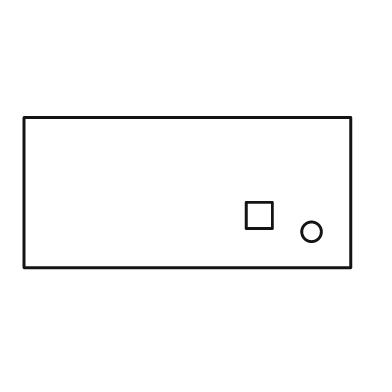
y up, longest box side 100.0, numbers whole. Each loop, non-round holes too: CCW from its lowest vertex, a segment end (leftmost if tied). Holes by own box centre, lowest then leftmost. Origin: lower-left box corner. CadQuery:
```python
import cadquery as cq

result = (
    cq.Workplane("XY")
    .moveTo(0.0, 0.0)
    .lineTo(100.0, 0.0)
    .lineTo(100.0, 46.0)
    .lineTo(0.0, 46.0)
    .close()
    .moveTo(88.0, 11.0)
    .circle(3.0)
    .moveTo(68.0, 12.0)
    .lineTo(76.0, 12.0)
    .lineTo(76.0, 20.0)
    .lineTo(68.0, 20.0)
    .close()
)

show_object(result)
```